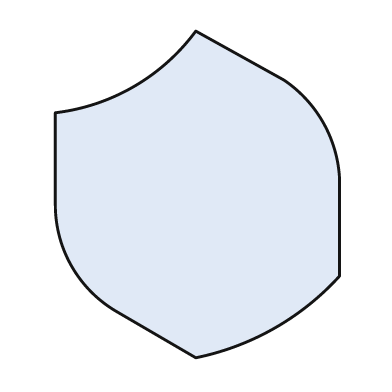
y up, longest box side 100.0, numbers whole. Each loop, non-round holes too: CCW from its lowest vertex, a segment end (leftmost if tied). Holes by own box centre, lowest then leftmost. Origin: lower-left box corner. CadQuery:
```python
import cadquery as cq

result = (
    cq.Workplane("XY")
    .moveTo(43.0, 0.0)
    .threePointArc((67.0, 9.0), (87.0, 25.0))
    .lineTo(87.0, 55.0)
    .threePointArc((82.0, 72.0), (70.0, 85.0))
    .lineTo(43.0, 100.0)
    .threePointArc((24.0, 83.0), (0.0, 75.0))
    .lineTo(0.0, 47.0)
    .threePointArc((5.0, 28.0), (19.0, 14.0))
    .close()
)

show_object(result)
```